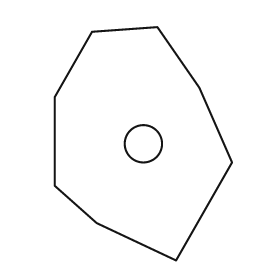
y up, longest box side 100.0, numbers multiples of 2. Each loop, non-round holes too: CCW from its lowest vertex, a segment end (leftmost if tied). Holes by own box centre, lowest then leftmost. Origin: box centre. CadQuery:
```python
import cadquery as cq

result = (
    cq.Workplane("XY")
    .moveTo(14.0, -50.0)
    .lineTo(38.0, -8.0)
    .lineTo(24.0, 24.0)
    .lineTo(6.0, 50.0)
    .lineTo(-22.0, 48.0)
    .lineTo(-38.0, 20.0)
    .lineTo(-38.0, -18.0)
    .lineTo(-20.0, -34.0)
    .close()
    .moveTo(0.0, 0.0)
    .circle(8.0)
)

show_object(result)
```